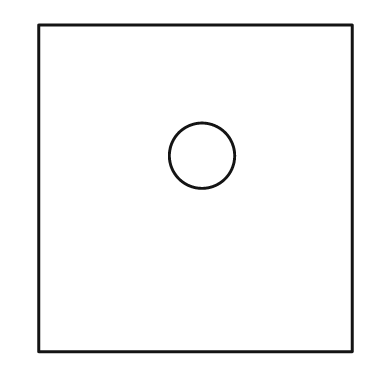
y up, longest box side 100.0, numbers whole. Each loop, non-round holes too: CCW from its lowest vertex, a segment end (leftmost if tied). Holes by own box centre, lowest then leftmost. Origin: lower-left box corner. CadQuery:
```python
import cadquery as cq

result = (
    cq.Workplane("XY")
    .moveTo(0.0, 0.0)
    .lineTo(96.0, 0.0)
    .lineTo(96.0, 100.0)
    .lineTo(0.0, 100.0)
    .close()
    .moveTo(50.0, 60.0)
    .circle(10.0)
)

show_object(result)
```